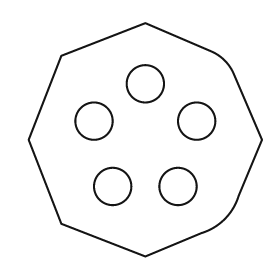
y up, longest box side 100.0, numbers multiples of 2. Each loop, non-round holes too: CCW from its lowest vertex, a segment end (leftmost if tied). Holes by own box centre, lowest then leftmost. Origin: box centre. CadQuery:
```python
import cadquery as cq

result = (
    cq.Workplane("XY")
    .moveTo(0.0, -50.0)
    .lineTo(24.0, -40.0)
    .threePointArc((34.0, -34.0), (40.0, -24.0))
    .lineTo(50.0, 0.0)
    .lineTo(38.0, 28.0)
    .threePointArc((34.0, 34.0), (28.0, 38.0))
    .lineTo(0.0, 50.0)
    .lineTo(-36.0, 36.0)
    .lineTo(-50.0, 0.0)
    .lineTo(-36.0, -36.0)
    .close()
    .moveTo(-14.0, -20.0)
    .circle(8.0)
    .moveTo(14.0, -20.0)
    .circle(8.0)
    .moveTo(-22.0, 8.0)
    .circle(8.0)
    .moveTo(22.0, 8.0)
    .circle(8.0)
    .moveTo(0.0, 24.0)
    .circle(8.0)
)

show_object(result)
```